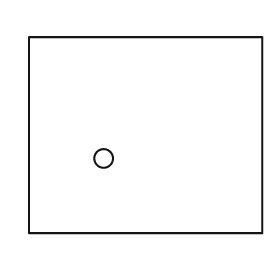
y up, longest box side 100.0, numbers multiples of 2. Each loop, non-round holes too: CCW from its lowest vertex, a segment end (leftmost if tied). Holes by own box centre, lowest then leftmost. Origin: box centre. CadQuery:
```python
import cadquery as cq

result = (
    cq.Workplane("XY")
    .moveTo(-50.0, -42.0)
    .lineTo(50.0, -42.0)
    .lineTo(50.0, 42.0)
    .lineTo(-50.0, 42.0)
    .close()
    .moveTo(-18.0, -10.0)
    .circle(4.0)
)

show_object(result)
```